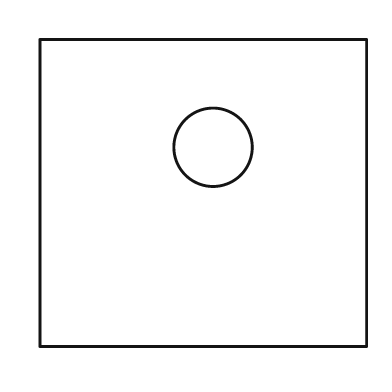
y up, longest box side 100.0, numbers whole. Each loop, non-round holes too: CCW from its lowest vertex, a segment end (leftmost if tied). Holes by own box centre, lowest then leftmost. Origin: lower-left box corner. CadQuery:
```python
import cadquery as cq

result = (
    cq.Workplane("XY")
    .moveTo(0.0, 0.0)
    .lineTo(100.0, 0.0)
    .lineTo(100.0, 94.0)
    .lineTo(0.0, 94.0)
    .close()
    .moveTo(53.0, 61.0)
    .circle(12.0)
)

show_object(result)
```